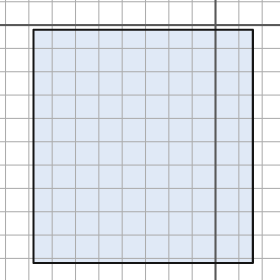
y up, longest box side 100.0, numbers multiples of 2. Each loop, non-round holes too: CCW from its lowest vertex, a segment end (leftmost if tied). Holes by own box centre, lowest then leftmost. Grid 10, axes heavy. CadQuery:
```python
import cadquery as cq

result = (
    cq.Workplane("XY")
    .moveTo(-78.0, -102.0)
    .lineTo(16.0, -102.0)
    .lineTo(16.0, -2.0)
    .lineTo(-78.0, -2.0)
    .close()
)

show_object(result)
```